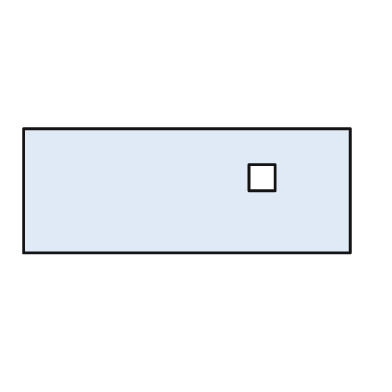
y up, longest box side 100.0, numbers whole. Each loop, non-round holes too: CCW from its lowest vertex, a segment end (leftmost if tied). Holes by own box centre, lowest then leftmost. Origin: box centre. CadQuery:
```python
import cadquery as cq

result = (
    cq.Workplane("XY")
    .moveTo(-50.0, -19.0)
    .lineTo(50.0, -19.0)
    .lineTo(50.0, 19.0)
    .lineTo(-50.0, 19.0)
    .close()
    .moveTo(19.0, 0.0)
    .lineTo(27.0, 0.0)
    .lineTo(27.0, 8.0)
    .lineTo(19.0, 8.0)
    .close()
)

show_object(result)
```